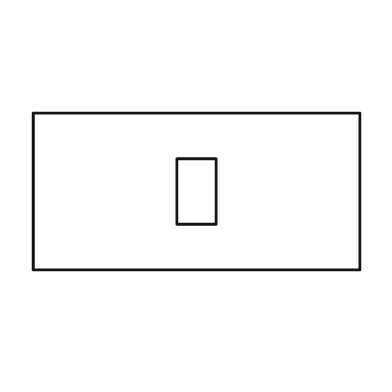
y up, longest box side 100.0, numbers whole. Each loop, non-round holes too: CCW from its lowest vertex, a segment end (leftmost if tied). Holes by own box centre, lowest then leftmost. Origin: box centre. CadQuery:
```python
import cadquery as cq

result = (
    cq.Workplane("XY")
    .moveTo(-50.0, -24.0)
    .lineTo(50.0, -24.0)
    .lineTo(50.0, 24.0)
    .lineTo(-50.0, 24.0)
    .close()
    .moveTo(-6.0, -10.0)
    .lineTo(6.0, -10.0)
    .lineTo(6.0, 10.0)
    .lineTo(-6.0, 10.0)
    .close()
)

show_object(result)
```